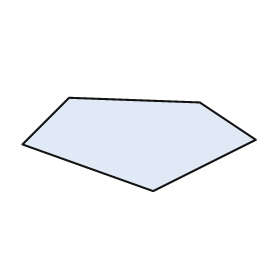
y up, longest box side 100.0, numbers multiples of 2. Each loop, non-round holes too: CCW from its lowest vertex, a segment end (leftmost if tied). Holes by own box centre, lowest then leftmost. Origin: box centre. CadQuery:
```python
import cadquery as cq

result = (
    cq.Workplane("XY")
    .moveTo(6.0, -20.0)
    .lineTo(50.0, 2.0)
    .lineTo(26.0, 18.0)
    .lineTo(-30.0, 20.0)
    .lineTo(-50.0, 0.0)
    .close()
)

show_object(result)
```